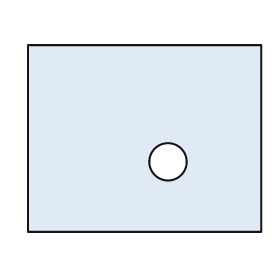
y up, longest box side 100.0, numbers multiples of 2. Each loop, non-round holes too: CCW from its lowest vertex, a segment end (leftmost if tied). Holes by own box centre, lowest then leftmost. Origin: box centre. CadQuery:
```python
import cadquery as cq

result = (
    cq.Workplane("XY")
    .moveTo(-50.0, -40.0)
    .lineTo(50.0, -40.0)
    .lineTo(50.0, 40.0)
    .lineTo(-50.0, 40.0)
    .close()
    .moveTo(10.0, -10.0)
    .circle(8.0)
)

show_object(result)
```